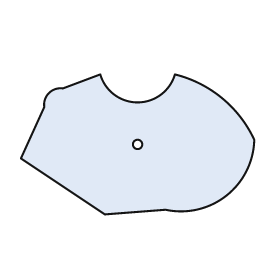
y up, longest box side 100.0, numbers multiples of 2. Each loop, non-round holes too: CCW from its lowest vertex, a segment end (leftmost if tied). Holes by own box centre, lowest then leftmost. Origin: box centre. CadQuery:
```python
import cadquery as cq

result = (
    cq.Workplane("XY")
    .moveTo(-14.0, -30.0)
    .lineTo(12.0, -28.0)
    .threePointArc((38.0, -22.0), (50.0, 2.0))
    .threePointArc((36.0, 20.0), (16.0, 30.0))
    .threePointArc((0.0, 18.0), (-16.0, 30.0))
    .lineTo(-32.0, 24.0)
    .threePointArc((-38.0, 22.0), (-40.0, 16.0))
    .lineTo(-50.0, -6.0)
    .close()
    .moveTo(0.0, 0.0)
    .circle(2.0)
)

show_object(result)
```